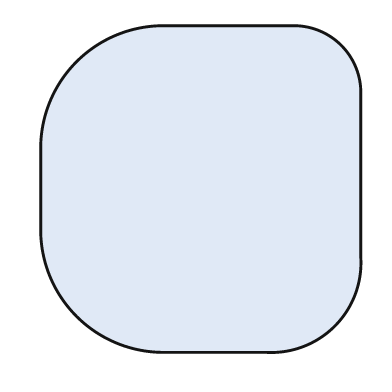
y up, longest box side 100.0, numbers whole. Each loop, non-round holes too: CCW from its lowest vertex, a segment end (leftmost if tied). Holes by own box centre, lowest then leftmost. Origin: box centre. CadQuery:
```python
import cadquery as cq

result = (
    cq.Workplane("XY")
    .moveTo(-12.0, -50.0)
    .lineTo(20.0, -50.0)
    .threePointArc((41.0, -42.0), (49.0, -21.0))
    .lineTo(49.0, 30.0)
    .threePointArc((43.0, 44.0), (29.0, 50.0))
    .lineTo(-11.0, 50.0)
    .threePointArc((-38.0, 39.0), (-49.0, 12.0))
    .lineTo(-49.0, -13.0)
    .threePointArc((-38.0, -39.0), (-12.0, -50.0))
    .close()
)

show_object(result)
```